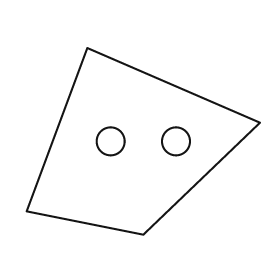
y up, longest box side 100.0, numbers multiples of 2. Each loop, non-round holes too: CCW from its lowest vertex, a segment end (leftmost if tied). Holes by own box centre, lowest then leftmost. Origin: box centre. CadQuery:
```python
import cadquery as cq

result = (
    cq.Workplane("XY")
    .moveTo(0.0, -40.0)
    .lineTo(50.0, 8.0)
    .lineTo(-24.0, 40.0)
    .lineTo(-50.0, -30.0)
    .close()
    .moveTo(-14.0, 0.0)
    .circle(6.0)
    .moveTo(14.0, 0.0)
    .circle(6.0)
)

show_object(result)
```